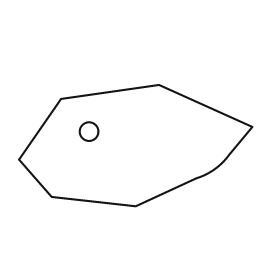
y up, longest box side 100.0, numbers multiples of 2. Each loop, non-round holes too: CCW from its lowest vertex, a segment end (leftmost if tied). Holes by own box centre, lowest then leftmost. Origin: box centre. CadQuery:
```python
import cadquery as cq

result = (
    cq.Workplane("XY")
    .moveTo(0.0, -26.0)
    .lineTo(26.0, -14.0)
    .threePointArc((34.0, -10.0), (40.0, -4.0))
    .lineTo(50.0, 8.0)
    .lineTo(10.0, 26.0)
    .lineTo(-32.0, 20.0)
    .lineTo(-50.0, -6.0)
    .lineTo(-36.0, -22.0)
    .close()
    .moveTo(-20.0, 6.0)
    .circle(4.0)
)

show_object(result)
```